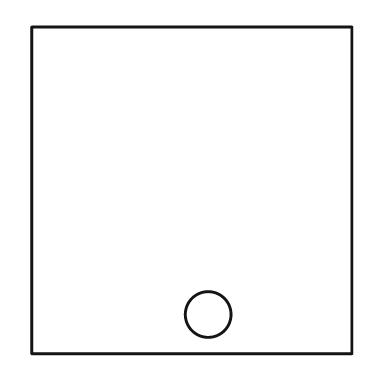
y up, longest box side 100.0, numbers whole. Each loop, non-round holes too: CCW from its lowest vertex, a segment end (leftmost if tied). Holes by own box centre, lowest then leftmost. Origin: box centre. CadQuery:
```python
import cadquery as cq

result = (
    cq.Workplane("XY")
    .moveTo(-49.0, -50.0)
    .lineTo(49.0, -50.0)
    .lineTo(49.0, 50.0)
    .lineTo(-49.0, 50.0)
    .close()
    .moveTo(5.0, -38.0)
    .circle(7.0)
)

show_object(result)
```